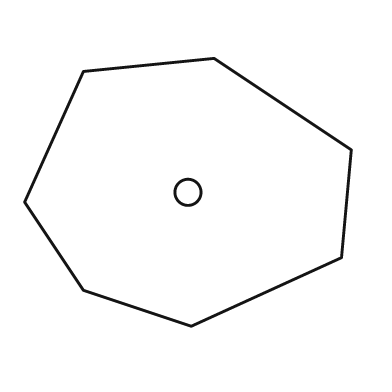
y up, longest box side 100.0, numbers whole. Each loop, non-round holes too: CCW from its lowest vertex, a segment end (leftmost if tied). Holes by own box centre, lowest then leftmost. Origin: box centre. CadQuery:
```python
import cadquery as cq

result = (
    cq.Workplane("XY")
    .moveTo(1.0, -41.0)
    .lineTo(47.0, -20.0)
    .lineTo(50.0, 13.0)
    .lineTo(8.0, 41.0)
    .lineTo(-32.0, 37.0)
    .lineTo(-50.0, -3.0)
    .lineTo(-32.0, -30.0)
    .close()
    .moveTo(0.0, 0.0)
    .circle(4.0)
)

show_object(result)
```